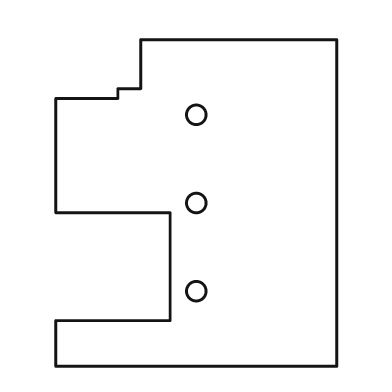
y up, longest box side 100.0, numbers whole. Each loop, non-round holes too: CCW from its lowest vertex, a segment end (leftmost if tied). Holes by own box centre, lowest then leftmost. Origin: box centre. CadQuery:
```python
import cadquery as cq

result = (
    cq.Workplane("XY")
    .moveTo(-43.0, -50.0)
    .lineTo(43.0, -50.0)
    .lineTo(43.0, 50.0)
    .lineTo(-17.0, 50.0)
    .lineTo(-17.0, 35.0)
    .lineTo(-24.0, 35.0)
    .lineTo(-24.0, 32.0)
    .lineTo(-43.0, 32.0)
    .lineTo(-43.0, -3.0)
    .lineTo(-8.0, -3.0)
    .lineTo(-8.0, -36.0)
    .lineTo(-43.0, -36.0)
    .close()
    .moveTo(0.0, -27.0)
    .circle(3.0)
    .moveTo(0.0, 0.0)
    .circle(3.0)
    .moveTo(0.0, 27.0)
    .circle(3.0)
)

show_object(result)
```